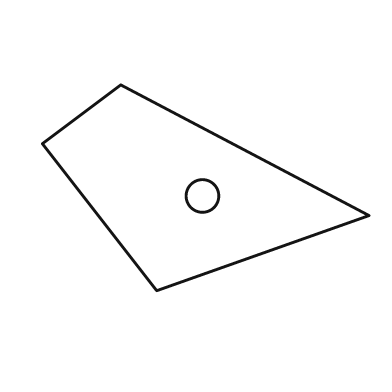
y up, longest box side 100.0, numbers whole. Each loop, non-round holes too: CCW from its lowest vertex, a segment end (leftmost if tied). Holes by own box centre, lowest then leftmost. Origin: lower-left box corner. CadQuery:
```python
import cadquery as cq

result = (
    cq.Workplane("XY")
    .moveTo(35.0, 0.0)
    .lineTo(100.0, 23.0)
    .lineTo(24.0, 63.0)
    .lineTo(0.0, 45.0)
    .close()
    .moveTo(49.0, 29.0)
    .circle(5.0)
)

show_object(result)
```